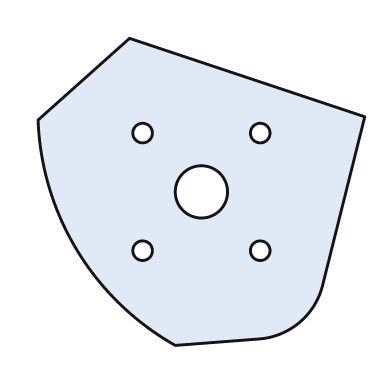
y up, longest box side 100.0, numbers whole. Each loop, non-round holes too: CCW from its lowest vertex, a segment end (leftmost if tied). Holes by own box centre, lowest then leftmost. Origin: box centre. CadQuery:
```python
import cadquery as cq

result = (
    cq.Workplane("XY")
    .moveTo(-8.0, -47.0)
    .lineTo(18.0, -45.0)
    .threePointArc((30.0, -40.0), (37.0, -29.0))
    .lineTo(50.0, 23.0)
    .lineTo(-22.0, 47.0)
    .lineTo(-50.0, 22.0)
    .threePointArc((-38.0, -18.0), (-8.0, -47.0))
    .close()
    .moveTo(-18.0, -18.0)
    .circle(3.0)
    .moveTo(18.0, -18.0)
    .circle(3.0)
    .moveTo(0.0, 0.0)
    .circle(8.0)
    .moveTo(-18.0, 18.0)
    .circle(3.0)
    .moveTo(18.0, 18.0)
    .circle(3.0)
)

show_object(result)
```